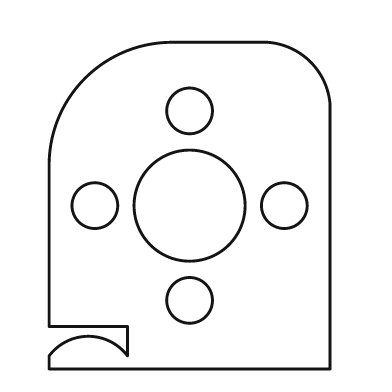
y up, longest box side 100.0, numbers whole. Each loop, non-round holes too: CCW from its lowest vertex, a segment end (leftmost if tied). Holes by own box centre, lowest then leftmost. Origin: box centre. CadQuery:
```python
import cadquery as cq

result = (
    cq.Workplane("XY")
    .moveTo(-43.0, -50.0)
    .lineTo(43.0, -50.0)
    .lineTo(43.0, 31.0)
    .threePointArc((37.0, 44.0), (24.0, 50.0))
    .lineTo(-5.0, 50.0)
    .threePointArc((-32.0, 39.0), (-43.0, 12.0))
    .lineTo(-43.0, -37.0)
    .lineTo(-19.0, -37.0)
    .lineTo(-19.0, -46.0)
    .threePointArc((-31.0, -40.0), (-43.0, -46.0))
    .close()
    .moveTo(0.0, -29.0)
    .circle(7.0)
    .moveTo(-29.0, 0.0)
    .circle(7.0)
    .moveTo(0.0, 0.0)
    .circle(17.0)
    .moveTo(29.0, 0.0)
    .circle(7.0)
    .moveTo(0.0, 29.0)
    .circle(7.0)
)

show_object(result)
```